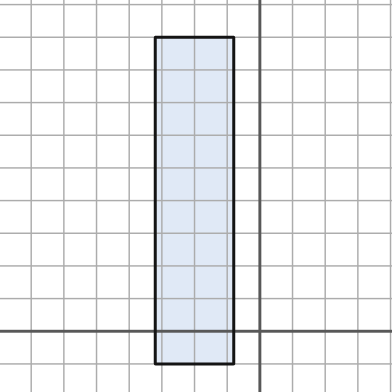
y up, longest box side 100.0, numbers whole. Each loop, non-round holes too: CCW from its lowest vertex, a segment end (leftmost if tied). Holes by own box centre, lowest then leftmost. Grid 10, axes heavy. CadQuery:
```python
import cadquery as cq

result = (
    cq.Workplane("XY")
    .moveTo(-32.0, -10.0)
    .lineTo(-8.0, -10.0)
    .lineTo(-8.0, 90.0)
    .lineTo(-32.0, 90.0)
    .close()
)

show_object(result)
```